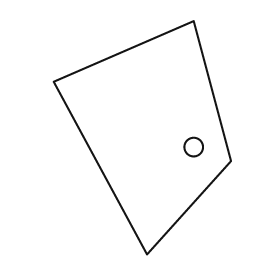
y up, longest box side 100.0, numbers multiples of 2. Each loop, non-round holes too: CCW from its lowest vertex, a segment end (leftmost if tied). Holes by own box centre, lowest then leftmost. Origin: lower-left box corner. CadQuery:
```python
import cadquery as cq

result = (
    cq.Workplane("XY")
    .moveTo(40.0, 0.0)
    .lineTo(76.0, 40.0)
    .lineTo(60.0, 100.0)
    .lineTo(0.0, 74.0)
    .close()
    .moveTo(60.0, 46.0)
    .circle(4.0)
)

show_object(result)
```